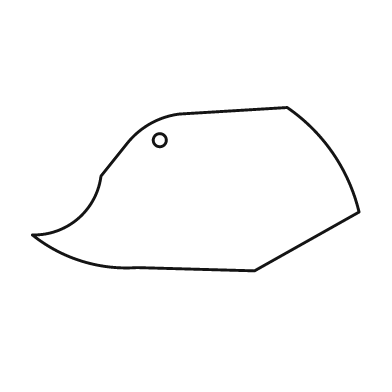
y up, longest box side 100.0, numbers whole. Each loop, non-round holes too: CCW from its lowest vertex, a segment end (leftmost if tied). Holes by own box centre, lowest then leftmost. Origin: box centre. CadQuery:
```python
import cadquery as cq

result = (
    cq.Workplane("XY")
    .moveTo(18.0, -25.0)
    .lineTo(50.0, -7.0)
    .threePointArc((42.0, 11.0), (28.0, 25.0))
    .lineTo(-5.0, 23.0)
    .threePointArc((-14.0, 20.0), (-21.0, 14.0))
    .lineTo(-29.0, 4.0)
    .threePointArc((-36.0, -9.0), (-50.0, -14.0))
    .threePointArc((-35.0, -22.0), (-18.0, -24.0))
    .close()
    .moveTo(-11.0, 15.0)
    .circle(2.0)
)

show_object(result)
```